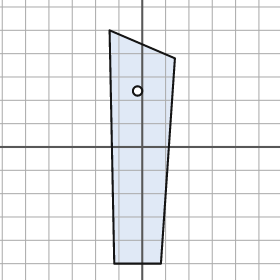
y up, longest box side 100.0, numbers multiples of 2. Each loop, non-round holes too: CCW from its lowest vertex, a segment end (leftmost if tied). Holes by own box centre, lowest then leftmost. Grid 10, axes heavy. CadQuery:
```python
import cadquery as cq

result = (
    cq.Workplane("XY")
    .moveTo(-12.0, -50.0)
    .lineTo(8.0, -50.0)
    .lineTo(14.0, 38.0)
    .lineTo(-14.0, 50.0)
    .close()
    .moveTo(-2.0, 24.0)
    .circle(2.0)
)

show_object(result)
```